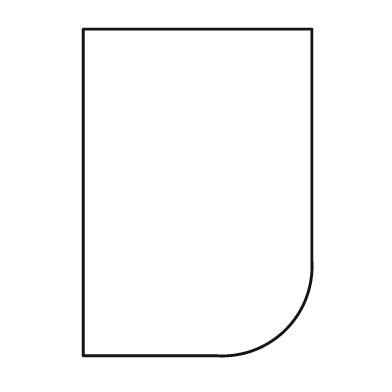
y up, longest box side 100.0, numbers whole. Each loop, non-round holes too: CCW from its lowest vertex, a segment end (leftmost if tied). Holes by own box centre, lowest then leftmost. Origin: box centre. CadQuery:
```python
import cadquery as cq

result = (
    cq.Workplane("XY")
    .moveTo(-35.0, -50.0)
    .lineTo(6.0, -50.0)
    .threePointArc((27.0, -42.0), (35.0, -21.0))
    .lineTo(35.0, 50.0)
    .lineTo(-35.0, 50.0)
    .close()
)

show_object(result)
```